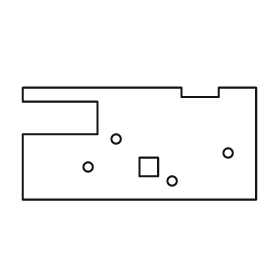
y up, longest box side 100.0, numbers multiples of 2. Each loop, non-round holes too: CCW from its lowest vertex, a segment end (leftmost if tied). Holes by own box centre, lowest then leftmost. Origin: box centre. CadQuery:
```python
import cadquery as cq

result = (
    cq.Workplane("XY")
    .moveTo(-50.0, -24.0)
    .lineTo(50.0, -24.0)
    .lineTo(50.0, 24.0)
    .lineTo(34.0, 24.0)
    .lineTo(34.0, 20.0)
    .lineTo(18.0, 20.0)
    .lineTo(18.0, 24.0)
    .lineTo(-50.0, 24.0)
    .lineTo(-50.0, 18.0)
    .lineTo(-18.0, 18.0)
    .lineTo(-18.0, 4.0)
    .lineTo(-50.0, 4.0)
    .close()
    .moveTo(14.0, -16.0)
    .circle(2.0)
    .moveTo(-22.0, -10.0)
    .circle(2.0)
    .moveTo(0.0, -14.0)
    .lineTo(8.0, -14.0)
    .lineTo(8.0, -6.0)
    .lineTo(0.0, -6.0)
    .close()
    .moveTo(38.0, -4.0)
    .circle(2.0)
    .moveTo(-10.0, 2.0)
    .circle(2.0)
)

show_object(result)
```